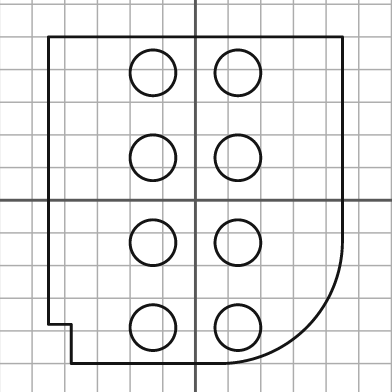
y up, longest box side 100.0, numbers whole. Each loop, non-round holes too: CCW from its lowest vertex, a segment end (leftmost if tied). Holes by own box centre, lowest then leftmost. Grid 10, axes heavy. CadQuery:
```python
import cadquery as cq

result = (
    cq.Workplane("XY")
    .moveTo(-38.0, -50.0)
    .lineTo(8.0, -50.0)
    .threePointArc((34.0, -39.0), (45.0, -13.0))
    .lineTo(45.0, 50.0)
    .lineTo(-45.0, 50.0)
    .lineTo(-45.0, -38.0)
    .lineTo(-38.0, -38.0)
    .close()
    .moveTo(-13.0, -39.0)
    .circle(7.0)
    .moveTo(13.0, -39.0)
    .circle(7.0)
    .moveTo(-13.0, -13.0)
    .circle(7.0)
    .moveTo(13.0, -13.0)
    .circle(7.0)
    .moveTo(-13.0, 13.0)
    .circle(7.0)
    .moveTo(13.0, 13.0)
    .circle(7.0)
    .moveTo(-13.0, 39.0)
    .circle(7.0)
    .moveTo(13.0, 39.0)
    .circle(7.0)
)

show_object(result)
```